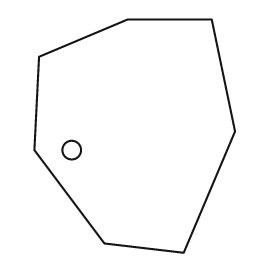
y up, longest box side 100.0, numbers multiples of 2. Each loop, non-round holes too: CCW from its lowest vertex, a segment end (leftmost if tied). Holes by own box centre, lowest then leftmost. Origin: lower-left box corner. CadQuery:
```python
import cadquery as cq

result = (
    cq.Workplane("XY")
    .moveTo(64.0, 0.0)
    .lineTo(86.0, 52.0)
    .lineTo(76.0, 100.0)
    .lineTo(40.0, 100.0)
    .lineTo(2.0, 84.0)
    .lineTo(0.0, 44.0)
    .lineTo(30.0, 4.0)
    .close()
    .moveTo(16.0, 44.0)
    .circle(4.0)
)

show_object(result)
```